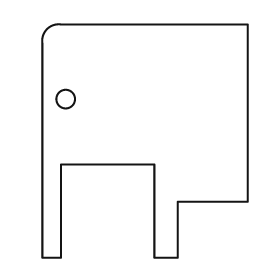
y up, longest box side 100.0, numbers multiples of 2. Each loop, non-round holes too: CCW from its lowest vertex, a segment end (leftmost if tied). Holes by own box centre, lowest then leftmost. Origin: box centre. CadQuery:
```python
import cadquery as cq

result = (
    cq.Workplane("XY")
    .moveTo(-44.0, -50.0)
    .lineTo(-36.0, -50.0)
    .lineTo(-36.0, -10.0)
    .lineTo(4.0, -10.0)
    .lineTo(4.0, -50.0)
    .lineTo(14.0, -50.0)
    .lineTo(14.0, -26.0)
    .lineTo(44.0, -26.0)
    .lineTo(44.0, 50.0)
    .lineTo(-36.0, 50.0)
    .threePointArc((-42.0, 48.0), (-44.0, 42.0))
    .close()
    .moveTo(-34.0, 18.0)
    .circle(4.0)
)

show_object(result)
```